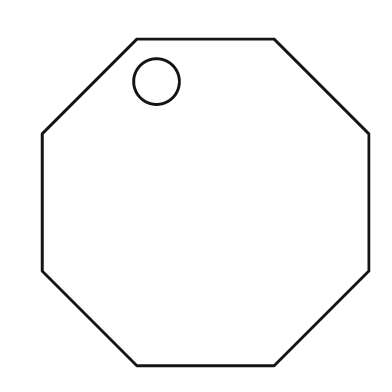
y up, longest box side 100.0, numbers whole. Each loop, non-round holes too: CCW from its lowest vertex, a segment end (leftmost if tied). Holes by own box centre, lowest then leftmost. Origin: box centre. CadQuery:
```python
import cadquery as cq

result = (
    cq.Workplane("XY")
    .moveTo(-21.0, -50.0)
    .lineTo(21.0, -50.0)
    .lineTo(50.0, -21.0)
    .lineTo(50.0, 21.0)
    .lineTo(21.0, 50.0)
    .lineTo(-21.0, 50.0)
    .lineTo(-50.0, 21.0)
    .lineTo(-50.0, -21.0)
    .close()
    .moveTo(-15.0, 37.0)
    .circle(7.0)
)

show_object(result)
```